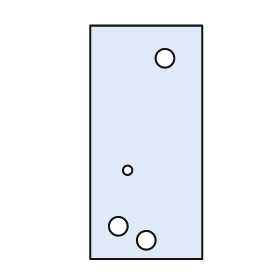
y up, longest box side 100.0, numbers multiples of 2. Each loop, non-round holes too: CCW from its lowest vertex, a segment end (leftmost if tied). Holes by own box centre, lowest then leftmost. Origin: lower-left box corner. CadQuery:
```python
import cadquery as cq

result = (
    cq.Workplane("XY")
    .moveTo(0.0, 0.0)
    .lineTo(48.0, 0.0)
    .lineTo(48.0, 100.0)
    .lineTo(0.0, 100.0)
    .close()
    .moveTo(24.0, 8.0)
    .circle(4.0)
    .moveTo(12.0, 14.0)
    .circle(4.0)
    .moveTo(16.0, 38.0)
    .circle(2.0)
    .moveTo(32.0, 86.0)
    .circle(4.0)
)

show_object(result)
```